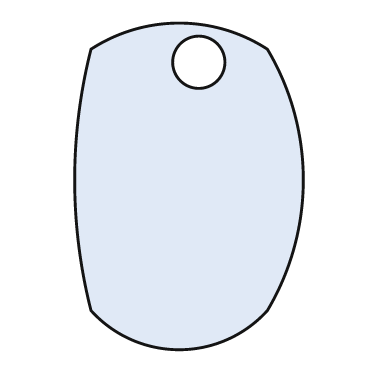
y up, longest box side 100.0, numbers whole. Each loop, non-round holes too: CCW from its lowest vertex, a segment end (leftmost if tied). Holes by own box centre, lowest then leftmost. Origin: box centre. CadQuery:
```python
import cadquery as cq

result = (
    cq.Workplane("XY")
    .moveTo(-30.0, -38.0)
    .threePointArc((-3.0, -50.0), (24.0, -38.0))
    .threePointArc((35.0, 2.0), (24.0, 42.0))
    .threePointArc((-3.0, 50.0), (-30.0, 42.0))
    .threePointArc((-35.0, 2.0), (-30.0, -38.0))
    .close()
    .moveTo(3.0, 38.0)
    .circle(8.0)
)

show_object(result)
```